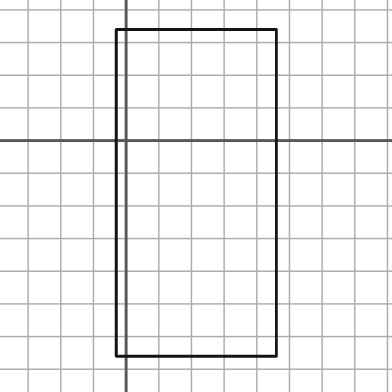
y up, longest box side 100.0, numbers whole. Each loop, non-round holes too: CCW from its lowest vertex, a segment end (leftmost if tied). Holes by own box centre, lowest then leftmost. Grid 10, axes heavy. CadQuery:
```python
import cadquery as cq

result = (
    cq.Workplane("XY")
    .moveTo(-3.0, -66.0)
    .lineTo(46.0, -66.0)
    .lineTo(46.0, 34.0)
    .lineTo(-3.0, 34.0)
    .close()
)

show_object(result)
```